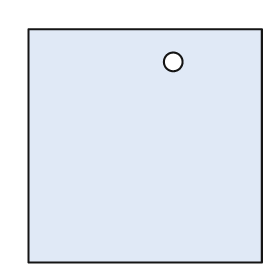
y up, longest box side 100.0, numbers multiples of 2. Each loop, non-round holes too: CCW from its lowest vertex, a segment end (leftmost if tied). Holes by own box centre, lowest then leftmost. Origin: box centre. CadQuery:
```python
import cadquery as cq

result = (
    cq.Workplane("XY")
    .moveTo(-50.0, -50.0)
    .lineTo(50.0, -50.0)
    .lineTo(50.0, 50.0)
    .lineTo(-50.0, 50.0)
    .close()
    .moveTo(12.0, 36.0)
    .circle(4.0)
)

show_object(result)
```